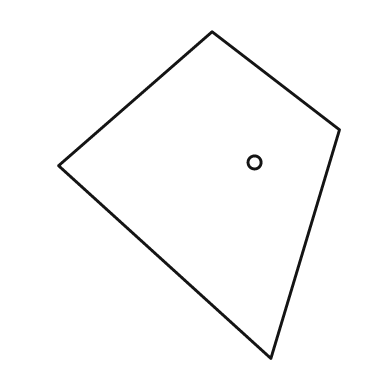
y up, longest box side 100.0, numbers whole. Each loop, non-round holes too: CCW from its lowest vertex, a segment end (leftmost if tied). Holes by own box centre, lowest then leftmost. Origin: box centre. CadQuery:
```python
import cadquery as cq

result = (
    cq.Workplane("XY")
    .moveTo(22.0, -50.0)
    .lineTo(43.0, 20.0)
    .lineTo(4.0, 50.0)
    .lineTo(-43.0, 9.0)
    .close()
    .moveTo(17.0, 10.0)
    .circle(2.0)
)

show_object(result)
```